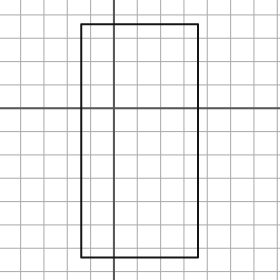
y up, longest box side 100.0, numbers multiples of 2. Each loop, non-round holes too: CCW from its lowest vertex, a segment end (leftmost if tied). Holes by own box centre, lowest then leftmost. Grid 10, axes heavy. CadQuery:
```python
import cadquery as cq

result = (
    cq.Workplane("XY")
    .moveTo(-14.0, -64.0)
    .lineTo(36.0, -64.0)
    .lineTo(36.0, 36.0)
    .lineTo(-14.0, 36.0)
    .close()
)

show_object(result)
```